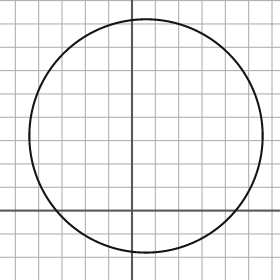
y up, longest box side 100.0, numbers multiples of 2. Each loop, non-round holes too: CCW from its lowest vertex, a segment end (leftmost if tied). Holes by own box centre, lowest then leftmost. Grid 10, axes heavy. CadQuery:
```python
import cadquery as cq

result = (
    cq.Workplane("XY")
    .moveTo(6.0, 32.0)
    .circle(50.0)
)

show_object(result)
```